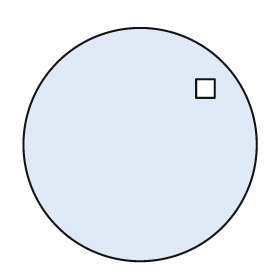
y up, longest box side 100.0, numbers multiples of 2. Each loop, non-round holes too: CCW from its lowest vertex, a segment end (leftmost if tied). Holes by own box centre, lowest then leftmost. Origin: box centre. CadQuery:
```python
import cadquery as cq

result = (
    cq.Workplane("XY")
    .moveTo(0.0, 0.0)
    .circle(50.0)
    .moveTo(24.0, 20.0)
    .lineTo(32.0, 20.0)
    .lineTo(32.0, 28.0)
    .lineTo(24.0, 28.0)
    .close()
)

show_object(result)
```